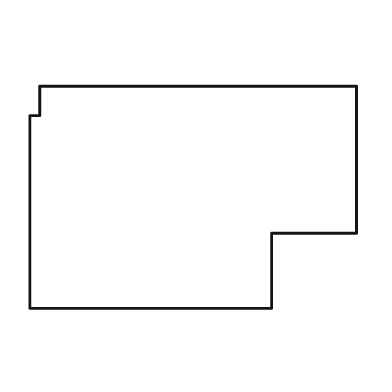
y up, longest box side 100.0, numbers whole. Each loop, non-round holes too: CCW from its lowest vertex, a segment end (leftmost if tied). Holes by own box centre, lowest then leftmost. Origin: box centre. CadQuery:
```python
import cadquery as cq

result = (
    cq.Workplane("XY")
    .moveTo(-50.0, -34.0)
    .lineTo(24.0, -34.0)
    .lineTo(24.0, -11.0)
    .lineTo(50.0, -11.0)
    .lineTo(50.0, 34.0)
    .lineTo(-47.0, 34.0)
    .lineTo(-47.0, 25.0)
    .lineTo(-50.0, 25.0)
    .close()
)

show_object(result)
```